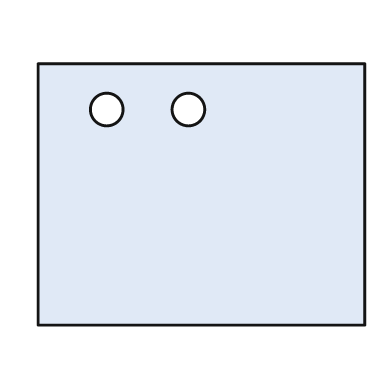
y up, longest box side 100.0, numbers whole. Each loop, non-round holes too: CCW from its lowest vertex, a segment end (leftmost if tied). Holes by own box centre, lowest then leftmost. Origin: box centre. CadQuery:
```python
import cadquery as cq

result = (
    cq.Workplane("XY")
    .moveTo(-50.0, -40.0)
    .lineTo(50.0, -40.0)
    .lineTo(50.0, 40.0)
    .lineTo(-50.0, 40.0)
    .close()
    .moveTo(-29.0, 26.0)
    .circle(5.0)
    .moveTo(-4.0, 26.0)
    .circle(5.0)
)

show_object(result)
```